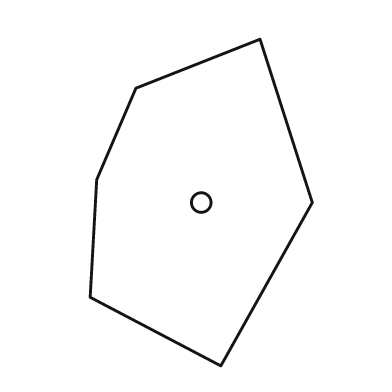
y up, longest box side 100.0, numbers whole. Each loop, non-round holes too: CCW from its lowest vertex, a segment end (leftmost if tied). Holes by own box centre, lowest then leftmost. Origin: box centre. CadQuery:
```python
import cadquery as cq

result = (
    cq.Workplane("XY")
    .moveTo(6.0, -50.0)
    .lineTo(34.0, 0.0)
    .lineTo(18.0, 50.0)
    .lineTo(-20.0, 35.0)
    .lineTo(-32.0, 7.0)
    .lineTo(-34.0, -29.0)
    .close()
    .moveTo(0.0, 0.0)
    .circle(3.0)
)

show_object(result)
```